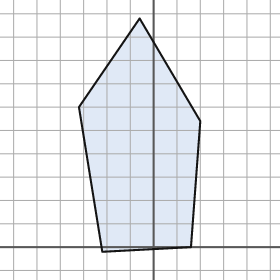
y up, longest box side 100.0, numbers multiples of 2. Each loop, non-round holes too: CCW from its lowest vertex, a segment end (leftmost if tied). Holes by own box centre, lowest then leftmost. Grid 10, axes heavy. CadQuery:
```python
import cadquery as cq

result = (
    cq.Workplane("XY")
    .moveTo(-22.0, -2.0)
    .lineTo(16.0, 0.0)
    .lineTo(20.0, 54.0)
    .lineTo(-6.0, 98.0)
    .lineTo(-32.0, 60.0)
    .close()
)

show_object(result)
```